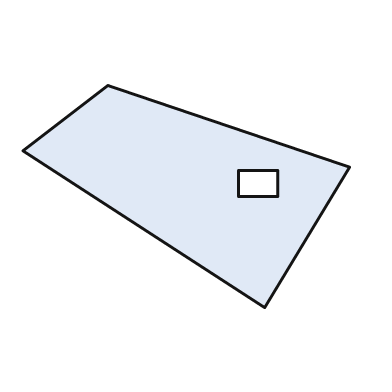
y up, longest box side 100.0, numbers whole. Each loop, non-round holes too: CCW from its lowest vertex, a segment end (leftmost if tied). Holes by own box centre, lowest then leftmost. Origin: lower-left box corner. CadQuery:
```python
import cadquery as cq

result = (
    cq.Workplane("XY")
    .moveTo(74.0, 0.0)
    .lineTo(100.0, 43.0)
    .lineTo(26.0, 68.0)
    .lineTo(0.0, 48.0)
    .close()
    .moveTo(66.0, 34.0)
    .lineTo(78.0, 34.0)
    .lineTo(78.0, 42.0)
    .lineTo(66.0, 42.0)
    .close()
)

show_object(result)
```